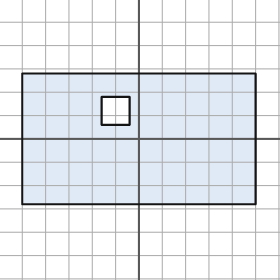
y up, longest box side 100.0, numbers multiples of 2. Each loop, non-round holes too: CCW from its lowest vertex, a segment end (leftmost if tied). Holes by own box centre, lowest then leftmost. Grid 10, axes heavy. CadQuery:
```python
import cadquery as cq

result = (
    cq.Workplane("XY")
    .moveTo(-50.0, -28.0)
    .lineTo(50.0, -28.0)
    .lineTo(50.0, 28.0)
    .lineTo(-50.0, 28.0)
    .close()
    .moveTo(-16.0, 6.0)
    .lineTo(-4.0, 6.0)
    .lineTo(-4.0, 18.0)
    .lineTo(-16.0, 18.0)
    .close()
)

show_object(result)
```